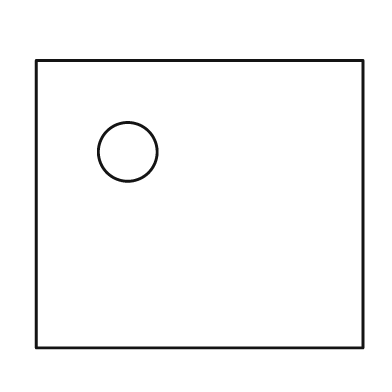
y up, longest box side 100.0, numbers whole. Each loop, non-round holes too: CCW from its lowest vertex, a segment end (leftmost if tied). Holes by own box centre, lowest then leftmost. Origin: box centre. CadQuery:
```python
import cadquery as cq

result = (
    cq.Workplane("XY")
    .moveTo(-50.0, -44.0)
    .lineTo(50.0, -44.0)
    .lineTo(50.0, 44.0)
    .lineTo(-50.0, 44.0)
    .close()
    .moveTo(-22.0, 16.0)
    .circle(9.0)
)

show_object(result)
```